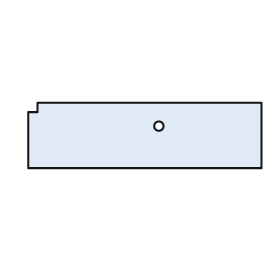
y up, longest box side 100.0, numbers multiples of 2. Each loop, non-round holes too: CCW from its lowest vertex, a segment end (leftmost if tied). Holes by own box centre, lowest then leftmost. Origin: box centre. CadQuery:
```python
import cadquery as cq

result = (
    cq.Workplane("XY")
    .moveTo(-50.0, -14.0)
    .lineTo(50.0, -14.0)
    .lineTo(50.0, 14.0)
    .lineTo(-46.0, 14.0)
    .lineTo(-46.0, 10.0)
    .lineTo(-50.0, 10.0)
    .close()
    .moveTo(6.0, 4.0)
    .circle(2.0)
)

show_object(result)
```